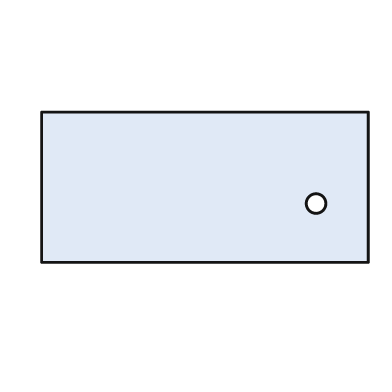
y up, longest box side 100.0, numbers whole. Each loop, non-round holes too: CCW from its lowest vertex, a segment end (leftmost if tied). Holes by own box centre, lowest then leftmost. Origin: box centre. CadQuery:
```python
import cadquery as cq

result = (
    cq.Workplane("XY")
    .moveTo(-50.0, -23.0)
    .lineTo(50.0, -23.0)
    .lineTo(50.0, 23.0)
    .lineTo(-50.0, 23.0)
    .close()
    .moveTo(34.0, -5.0)
    .circle(3.0)
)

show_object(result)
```